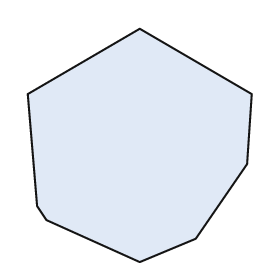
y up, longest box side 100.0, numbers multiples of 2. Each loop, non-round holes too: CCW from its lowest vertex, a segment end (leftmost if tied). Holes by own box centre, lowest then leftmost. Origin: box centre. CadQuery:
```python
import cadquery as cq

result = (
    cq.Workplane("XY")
    .moveTo(0.0, -50.0)
    .lineTo(24.0, -40.0)
    .lineTo(46.0, -8.0)
    .lineTo(48.0, 22.0)
    .lineTo(0.0, 50.0)
    .lineTo(-48.0, 22.0)
    .lineTo(-44.0, -26.0)
    .lineTo(-40.0, -32.0)
    .close()
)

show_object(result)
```